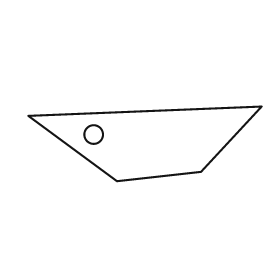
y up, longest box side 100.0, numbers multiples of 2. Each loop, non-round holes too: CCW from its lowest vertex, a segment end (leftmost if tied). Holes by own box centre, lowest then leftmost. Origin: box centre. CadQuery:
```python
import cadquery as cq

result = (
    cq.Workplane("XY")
    .moveTo(-12.0, -16.0)
    .lineTo(24.0, -12.0)
    .lineTo(50.0, 16.0)
    .lineTo(-50.0, 12.0)
    .close()
    .moveTo(-22.0, 4.0)
    .circle(4.0)
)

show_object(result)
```